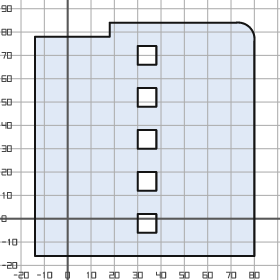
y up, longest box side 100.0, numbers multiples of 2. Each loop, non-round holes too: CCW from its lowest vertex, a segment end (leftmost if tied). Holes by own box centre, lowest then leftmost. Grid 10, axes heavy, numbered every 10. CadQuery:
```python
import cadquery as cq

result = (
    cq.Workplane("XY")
    .moveTo(-14.0, -16.0)
    .lineTo(80.0, -16.0)
    .lineTo(80.0, 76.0)
    .threePointArc((78.0, 82.0), (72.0, 84.0))
    .lineTo(18.0, 84.0)
    .lineTo(18.0, 78.0)
    .lineTo(-14.0, 78.0)
    .close()
    .moveTo(30.0, -6.0)
    .lineTo(38.0, -6.0)
    .lineTo(38.0, 2.0)
    .lineTo(30.0, 2.0)
    .close()
    .moveTo(30.0, 12.0)
    .lineTo(38.0, 12.0)
    .lineTo(38.0, 20.0)
    .lineTo(30.0, 20.0)
    .close()
    .moveTo(30.0, 30.0)
    .lineTo(38.0, 30.0)
    .lineTo(38.0, 38.0)
    .lineTo(30.0, 38.0)
    .close()
    .moveTo(30.0, 48.0)
    .lineTo(38.0, 48.0)
    .lineTo(38.0, 56.0)
    .lineTo(30.0, 56.0)
    .close()
    .moveTo(30.0, 66.0)
    .lineTo(38.0, 66.0)
    .lineTo(38.0, 74.0)
    .lineTo(30.0, 74.0)
    .close()
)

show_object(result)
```